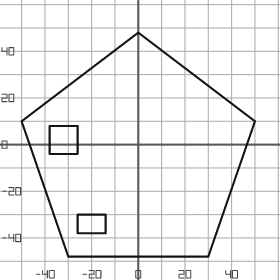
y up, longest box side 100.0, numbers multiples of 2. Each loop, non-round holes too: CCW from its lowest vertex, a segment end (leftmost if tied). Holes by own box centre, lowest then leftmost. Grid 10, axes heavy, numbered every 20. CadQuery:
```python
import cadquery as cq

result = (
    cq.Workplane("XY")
    .moveTo(-30.0, -48.0)
    .lineTo(30.0, -48.0)
    .lineTo(50.0, 10.0)
    .lineTo(0.0, 48.0)
    .lineTo(-50.0, 10.0)
    .close()
    .moveTo(-26.0, -38.0)
    .lineTo(-14.0, -38.0)
    .lineTo(-14.0, -30.0)
    .lineTo(-26.0, -30.0)
    .close()
    .moveTo(-38.0, -4.0)
    .lineTo(-26.0, -4.0)
    .lineTo(-26.0, 8.0)
    .lineTo(-38.0, 8.0)
    .close()
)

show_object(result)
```